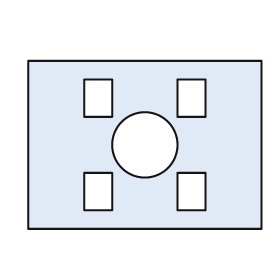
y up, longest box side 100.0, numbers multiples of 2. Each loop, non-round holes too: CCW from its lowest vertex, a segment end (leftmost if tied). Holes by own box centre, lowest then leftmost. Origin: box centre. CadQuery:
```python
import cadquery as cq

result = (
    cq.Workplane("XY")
    .moveTo(-50.0, -36.0)
    .lineTo(50.0, -36.0)
    .lineTo(50.0, 36.0)
    .lineTo(-50.0, 36.0)
    .close()
    .moveTo(-26.0, -28.0)
    .lineTo(-14.0, -28.0)
    .lineTo(-14.0, -12.0)
    .lineTo(-26.0, -12.0)
    .close()
    .moveTo(14.0, -28.0)
    .lineTo(26.0, -28.0)
    .lineTo(26.0, -12.0)
    .lineTo(14.0, -12.0)
    .close()
    .moveTo(0.0, 0.0)
    .circle(14.0)
    .moveTo(-26.0, 12.0)
    .lineTo(-14.0, 12.0)
    .lineTo(-14.0, 28.0)
    .lineTo(-26.0, 28.0)
    .close()
    .moveTo(14.0, 12.0)
    .lineTo(26.0, 12.0)
    .lineTo(26.0, 28.0)
    .lineTo(14.0, 28.0)
    .close()
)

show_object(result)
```